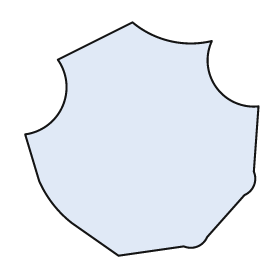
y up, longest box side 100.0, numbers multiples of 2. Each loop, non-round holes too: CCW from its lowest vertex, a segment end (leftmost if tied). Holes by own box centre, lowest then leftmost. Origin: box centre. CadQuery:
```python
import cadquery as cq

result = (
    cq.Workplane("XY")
    .moveTo(-10.0, -50.0)
    .lineTo(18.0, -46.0)
    .threePointArc((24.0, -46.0), (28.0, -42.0))
    .lineTo(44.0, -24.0)
    .threePointArc((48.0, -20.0), (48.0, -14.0))
    .lineTo(50.0, 14.0)
    .threePointArc((32.0, 22.0), (30.0, 42.0))
    .threePointArc((12.0, 42.0), (-4.0, 50.0))
    .lineTo(-36.0, 34.0)
    .threePointArc((-34.0, 14.0), (-50.0, 2.0))
    .lineTo(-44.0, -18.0)
    .threePointArc((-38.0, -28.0), (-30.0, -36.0))
    .close()
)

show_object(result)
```